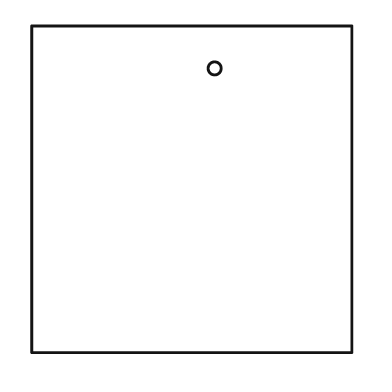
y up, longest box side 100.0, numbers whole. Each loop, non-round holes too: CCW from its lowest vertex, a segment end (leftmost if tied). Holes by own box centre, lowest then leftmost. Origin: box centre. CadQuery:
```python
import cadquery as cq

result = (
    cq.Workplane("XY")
    .moveTo(-49.0, -50.0)
    .lineTo(49.0, -50.0)
    .lineTo(49.0, 50.0)
    .lineTo(-49.0, 50.0)
    .close()
    .moveTo(7.0, 37.0)
    .circle(2.0)
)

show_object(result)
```